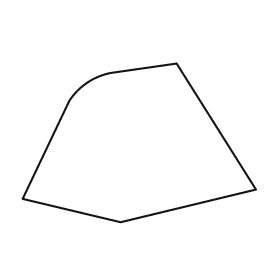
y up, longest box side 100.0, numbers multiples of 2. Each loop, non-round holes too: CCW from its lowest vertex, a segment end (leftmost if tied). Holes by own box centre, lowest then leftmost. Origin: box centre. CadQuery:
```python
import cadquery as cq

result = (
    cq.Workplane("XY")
    .moveTo(-8.0, -34.0)
    .lineTo(50.0, -20.0)
    .lineTo(16.0, 34.0)
    .lineTo(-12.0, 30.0)
    .threePointArc((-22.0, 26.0), (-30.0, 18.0))
    .lineTo(-50.0, -24.0)
    .close()
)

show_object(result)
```